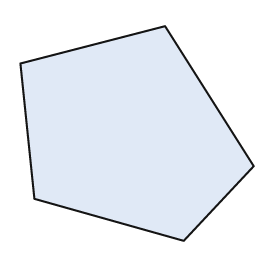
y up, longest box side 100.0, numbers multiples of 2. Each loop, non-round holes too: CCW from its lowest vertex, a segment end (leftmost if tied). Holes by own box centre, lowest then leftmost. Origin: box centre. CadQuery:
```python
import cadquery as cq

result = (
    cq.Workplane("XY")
    .moveTo(20.0, -46.0)
    .lineTo(50.0, -14.0)
    .lineTo(12.0, 46.0)
    .lineTo(-50.0, 30.0)
    .lineTo(-44.0, -28.0)
    .close()
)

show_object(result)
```